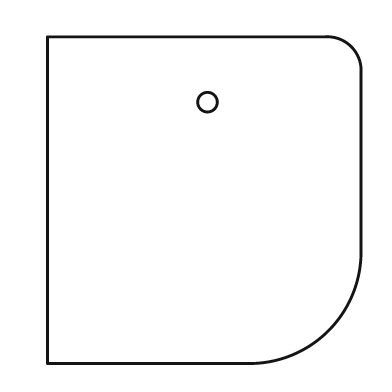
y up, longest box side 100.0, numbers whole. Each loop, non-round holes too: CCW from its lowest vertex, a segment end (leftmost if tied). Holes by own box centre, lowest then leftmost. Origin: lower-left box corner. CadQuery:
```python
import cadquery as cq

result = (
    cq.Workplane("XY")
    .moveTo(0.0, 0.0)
    .lineTo(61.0, 0.0)
    .threePointArc((86.0, 10.0), (96.0, 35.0))
    .lineTo(96.0, 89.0)
    .threePointArc((93.0, 97.0), (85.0, 100.0))
    .lineTo(0.0, 100.0)
    .close()
    .moveTo(49.0, 80.0)
    .circle(3.0)
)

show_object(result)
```